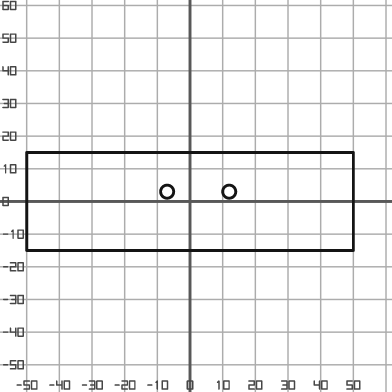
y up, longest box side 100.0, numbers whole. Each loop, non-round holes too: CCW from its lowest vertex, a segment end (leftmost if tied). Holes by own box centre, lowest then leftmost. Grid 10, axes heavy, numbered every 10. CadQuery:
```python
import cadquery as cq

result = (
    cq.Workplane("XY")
    .moveTo(-50.0, -15.0)
    .lineTo(50.0, -15.0)
    .lineTo(50.0, 15.0)
    .lineTo(-50.0, 15.0)
    .close()
    .moveTo(-7.0, 3.0)
    .circle(2.0)
    .moveTo(12.0, 3.0)
    .circle(2.0)
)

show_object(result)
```